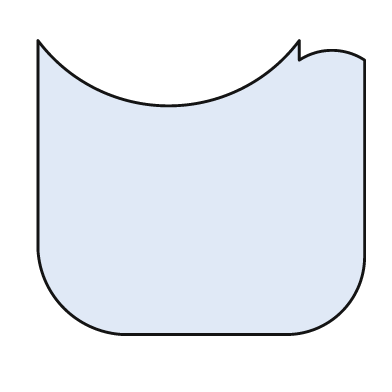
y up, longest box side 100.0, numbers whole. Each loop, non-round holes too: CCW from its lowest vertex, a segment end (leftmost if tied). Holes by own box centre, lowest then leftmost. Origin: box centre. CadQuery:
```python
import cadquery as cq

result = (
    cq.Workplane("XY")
    .moveTo(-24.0, -45.0)
    .lineTo(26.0, -45.0)
    .threePointArc((43.0, -38.0), (50.0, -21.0))
    .lineTo(50.0, 39.0)
    .threePointArc((40.0, 42.0), (30.0, 39.0))
    .lineTo(30.0, 45.0)
    .threePointArc((-10.0, 25.0), (-50.0, 45.0))
    .lineTo(-50.0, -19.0)
    .threePointArc((-42.0, -37.0), (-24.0, -45.0))
    .close()
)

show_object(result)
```